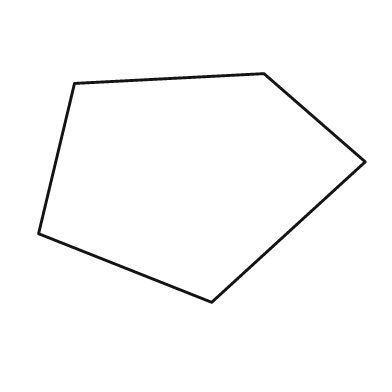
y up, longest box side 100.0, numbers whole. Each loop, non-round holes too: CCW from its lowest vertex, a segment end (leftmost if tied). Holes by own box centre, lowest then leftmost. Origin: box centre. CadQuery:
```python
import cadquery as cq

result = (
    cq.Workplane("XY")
    .moveTo(3.0, -35.0)
    .lineTo(50.0, 8.0)
    .lineTo(19.0, 35.0)
    .lineTo(-39.0, 32.0)
    .lineTo(-50.0, -14.0)
    .close()
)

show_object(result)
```